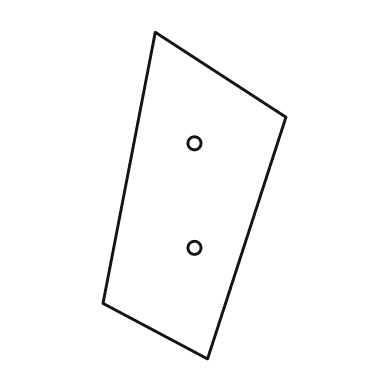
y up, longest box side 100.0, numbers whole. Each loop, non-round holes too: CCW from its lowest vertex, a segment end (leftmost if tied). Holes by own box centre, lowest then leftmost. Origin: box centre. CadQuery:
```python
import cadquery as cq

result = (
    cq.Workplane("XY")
    .moveTo(4.0, -50.0)
    .lineTo(28.0, 24.0)
    .lineTo(-12.0, 50.0)
    .lineTo(-28.0, -33.0)
    .close()
    .moveTo(0.0, -16.0)
    .circle(2.0)
    .moveTo(0.0, 16.0)
    .circle(2.0)
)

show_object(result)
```